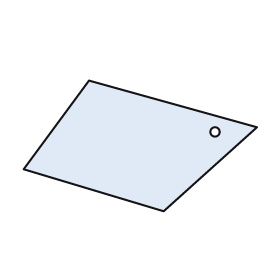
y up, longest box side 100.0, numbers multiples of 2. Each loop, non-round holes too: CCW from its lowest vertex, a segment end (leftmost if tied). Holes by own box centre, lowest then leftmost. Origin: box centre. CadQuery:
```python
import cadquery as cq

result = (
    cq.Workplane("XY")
    .moveTo(10.0, -28.0)
    .lineTo(50.0, 8.0)
    .lineTo(-22.0, 28.0)
    .lineTo(-50.0, -10.0)
    .close()
    .moveTo(32.0, 6.0)
    .circle(2.0)
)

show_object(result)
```